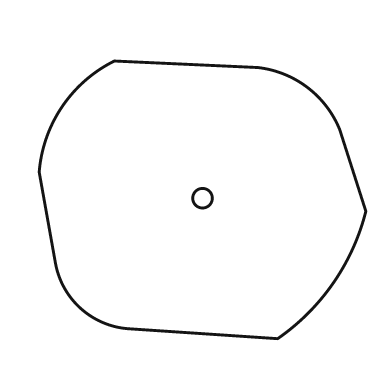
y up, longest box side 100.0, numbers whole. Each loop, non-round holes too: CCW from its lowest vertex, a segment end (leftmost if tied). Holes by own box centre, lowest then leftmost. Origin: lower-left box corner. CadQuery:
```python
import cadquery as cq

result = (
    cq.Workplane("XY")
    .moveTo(73.0, 0.0)
    .threePointArc((90.0, 17.0), (100.0, 39.0))
    .lineTo(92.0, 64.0)
    .threePointArc((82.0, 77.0), (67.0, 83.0))
    .lineTo(23.0, 85.0)
    .threePointArc((7.0, 71.0), (0.0, 51.0))
    .lineTo(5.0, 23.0)
    .threePointArc((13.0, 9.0), (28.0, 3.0))
    .close()
    .moveTo(50.0, 43.0)
    .circle(3.0)
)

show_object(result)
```